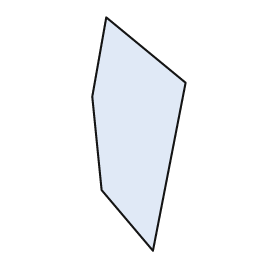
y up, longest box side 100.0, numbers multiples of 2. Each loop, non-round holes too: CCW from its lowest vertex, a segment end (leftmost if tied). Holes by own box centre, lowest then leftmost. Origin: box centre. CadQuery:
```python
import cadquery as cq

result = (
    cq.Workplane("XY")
    .moveTo(6.0, -50.0)
    .lineTo(20.0, 22.0)
    .lineTo(-14.0, 50.0)
    .lineTo(-20.0, 16.0)
    .lineTo(-16.0, -24.0)
    .close()
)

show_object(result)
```